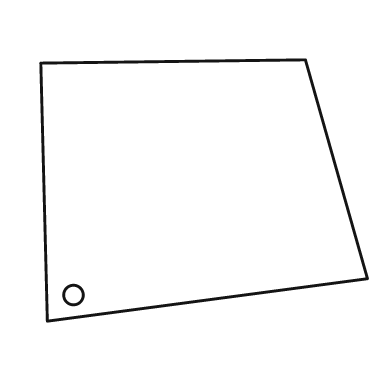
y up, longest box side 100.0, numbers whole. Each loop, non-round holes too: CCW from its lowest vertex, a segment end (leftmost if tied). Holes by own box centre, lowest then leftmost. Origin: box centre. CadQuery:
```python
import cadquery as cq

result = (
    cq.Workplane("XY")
    .moveTo(-48.0, -40.0)
    .lineTo(50.0, -27.0)
    .lineTo(31.0, 40.0)
    .lineTo(-50.0, 39.0)
    .close()
    .moveTo(-40.0, -32.0)
    .circle(3.0)
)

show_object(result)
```